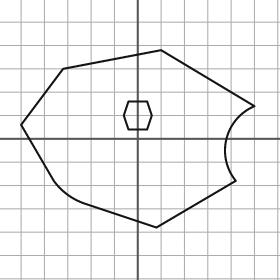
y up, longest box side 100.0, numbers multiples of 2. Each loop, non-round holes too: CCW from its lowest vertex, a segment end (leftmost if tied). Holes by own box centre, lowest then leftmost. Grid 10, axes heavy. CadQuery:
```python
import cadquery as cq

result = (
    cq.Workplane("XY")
    .moveTo(8.0, -38.0)
    .lineTo(42.0, -18.0)
    .threePointArc((38.0, 0.0), (50.0, 14.0))
    .lineTo(10.0, 38.0)
    .lineTo(-32.0, 30.0)
    .lineTo(-50.0, 6.0)
    .lineTo(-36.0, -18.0)
    .threePointArc((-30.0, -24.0), (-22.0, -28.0))
    .close()
    .moveTo(-4.0, 4.0)
    .lineTo(4.0, 4.0)
    .lineTo(6.0, 10.0)
    .lineTo(4.0, 16.0)
    .lineTo(-4.0, 16.0)
    .lineTo(-6.0, 10.0)
    .close()
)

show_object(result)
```